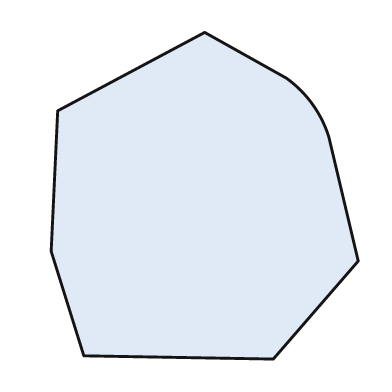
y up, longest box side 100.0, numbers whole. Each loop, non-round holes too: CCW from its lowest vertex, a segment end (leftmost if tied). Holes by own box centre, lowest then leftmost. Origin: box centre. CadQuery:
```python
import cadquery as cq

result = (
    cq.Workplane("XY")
    .moveTo(21.0, -50.0)
    .lineTo(47.0, -20.0)
    .lineTo(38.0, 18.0)
    .threePointArc((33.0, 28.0), (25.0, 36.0))
    .lineTo(0.0, 50.0)
    .lineTo(-45.0, 26.0)
    .lineTo(-47.0, -17.0)
    .lineTo(-37.0, -49.0)
    .close()
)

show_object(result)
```